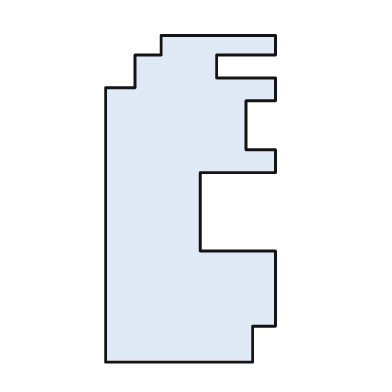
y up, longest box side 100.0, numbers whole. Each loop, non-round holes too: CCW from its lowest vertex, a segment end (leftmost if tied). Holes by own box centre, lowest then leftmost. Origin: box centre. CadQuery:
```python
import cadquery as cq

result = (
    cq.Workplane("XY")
    .moveTo(-26.0, -50.0)
    .lineTo(19.0, -50.0)
    .lineTo(19.0, -39.0)
    .lineTo(26.0, -39.0)
    .lineTo(26.0, -16.0)
    .lineTo(3.0, -16.0)
    .lineTo(3.0, 8.0)
    .lineTo(26.0, 8.0)
    .lineTo(26.0, 15.0)
    .lineTo(17.0, 15.0)
    .lineTo(17.0, 30.0)
    .lineTo(26.0, 30.0)
    .lineTo(26.0, 37.0)
    .lineTo(8.0, 37.0)
    .lineTo(8.0, 44.0)
    .lineTo(26.0, 44.0)
    .lineTo(26.0, 50.0)
    .lineTo(-9.0, 50.0)
    .lineTo(-9.0, 44.0)
    .lineTo(-17.0, 44.0)
    .lineTo(-17.0, 34.0)
    .lineTo(-26.0, 34.0)
    .close()
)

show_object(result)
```